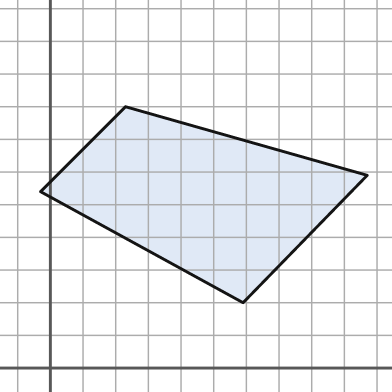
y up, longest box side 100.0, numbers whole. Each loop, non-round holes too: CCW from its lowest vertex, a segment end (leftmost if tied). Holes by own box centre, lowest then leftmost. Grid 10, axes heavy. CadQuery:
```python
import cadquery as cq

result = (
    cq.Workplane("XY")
    .moveTo(59.0, 20.0)
    .lineTo(97.0, 59.0)
    .lineTo(23.0, 80.0)
    .lineTo(-3.0, 54.0)
    .close()
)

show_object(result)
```